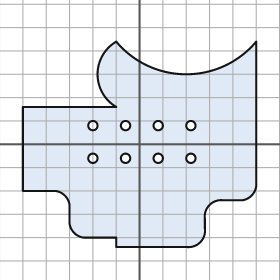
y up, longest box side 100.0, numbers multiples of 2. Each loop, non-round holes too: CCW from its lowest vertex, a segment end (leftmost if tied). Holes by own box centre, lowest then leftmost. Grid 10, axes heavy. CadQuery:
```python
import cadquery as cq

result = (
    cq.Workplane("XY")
    .moveTo(-10.0, -44.0)
    .lineTo(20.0, -44.0)
    .threePointArc((26.0, -42.0), (28.0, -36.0))
    .lineTo(28.0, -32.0)
    .threePointArc((30.0, -26.0), (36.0, -24.0))
    .lineTo(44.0, -24.0)
    .threePointArc((48.0, -22.0), (50.0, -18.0))
    .lineTo(50.0, 44.0)
    .threePointArc((20.0, 30.0), (-10.0, 44.0))
    .threePointArc((-18.0, 30.0), (-10.0, 16.0))
    .lineTo(-50.0, 16.0)
    .lineTo(-50.0, -20.0)
    .lineTo(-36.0, -20.0)
    .threePointArc((-32.0, -22.0), (-30.0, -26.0))
    .lineTo(-30.0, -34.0)
    .threePointArc((-28.0, -38.0), (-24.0, -40.0))
    .lineTo(-10.0, -40.0)
    .close()
    .moveTo(-20.0, -6.0)
    .circle(2.0)
    .moveTo(-6.0, -6.0)
    .circle(2.0)
    .moveTo(8.0, -6.0)
    .circle(2.0)
    .moveTo(22.0, -6.0)
    .circle(2.0)
    .moveTo(-20.0, 8.0)
    .circle(2.0)
    .moveTo(-6.0, 8.0)
    .circle(2.0)
    .moveTo(8.0, 8.0)
    .circle(2.0)
    .moveTo(22.0, 8.0)
    .circle(2.0)
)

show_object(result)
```